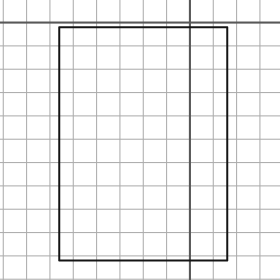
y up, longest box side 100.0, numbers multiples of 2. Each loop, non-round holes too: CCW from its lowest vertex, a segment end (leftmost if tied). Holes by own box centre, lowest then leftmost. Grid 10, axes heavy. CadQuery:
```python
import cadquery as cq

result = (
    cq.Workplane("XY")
    .moveTo(-56.0, -102.0)
    .lineTo(16.0, -102.0)
    .lineTo(16.0, -2.0)
    .lineTo(-56.0, -2.0)
    .close()
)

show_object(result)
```